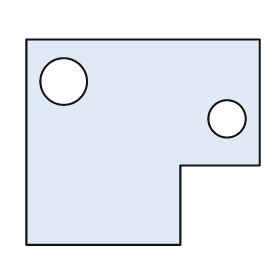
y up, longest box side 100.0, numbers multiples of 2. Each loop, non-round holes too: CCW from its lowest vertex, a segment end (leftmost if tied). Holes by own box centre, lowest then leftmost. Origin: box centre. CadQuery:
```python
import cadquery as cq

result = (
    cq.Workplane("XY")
    .moveTo(-50.0, -44.0)
    .lineTo(16.0, -44.0)
    .lineTo(16.0, -10.0)
    .lineTo(50.0, -10.0)
    .lineTo(50.0, 44.0)
    .lineTo(-50.0, 44.0)
    .close()
    .moveTo(36.0, 10.0)
    .circle(8.0)
    .moveTo(-34.0, 26.0)
    .circle(10.0)
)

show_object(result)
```